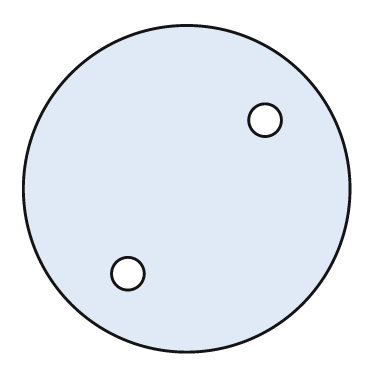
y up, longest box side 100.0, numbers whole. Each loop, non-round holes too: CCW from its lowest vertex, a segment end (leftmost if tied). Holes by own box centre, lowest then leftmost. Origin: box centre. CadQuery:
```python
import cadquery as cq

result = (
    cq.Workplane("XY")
    .moveTo(0.0, 0.0)
    .circle(50.0)
    .moveTo(-18.0, -26.0)
    .circle(5.0)
    .moveTo(24.0, 21.0)
    .circle(5.0)
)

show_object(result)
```